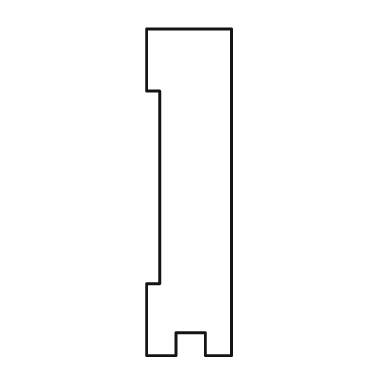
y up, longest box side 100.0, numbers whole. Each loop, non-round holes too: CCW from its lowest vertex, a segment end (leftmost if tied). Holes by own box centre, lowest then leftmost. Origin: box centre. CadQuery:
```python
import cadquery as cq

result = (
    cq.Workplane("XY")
    .moveTo(-13.0, -50.0)
    .lineTo(-4.0, -50.0)
    .lineTo(-4.0, -43.0)
    .lineTo(5.0, -43.0)
    .lineTo(5.0, -50.0)
    .lineTo(13.0, -50.0)
    .lineTo(13.0, 50.0)
    .lineTo(-13.0, 50.0)
    .lineTo(-13.0, 31.0)
    .lineTo(-9.0, 31.0)
    .lineTo(-9.0, -28.0)
    .lineTo(-13.0, -28.0)
    .close()
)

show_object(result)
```